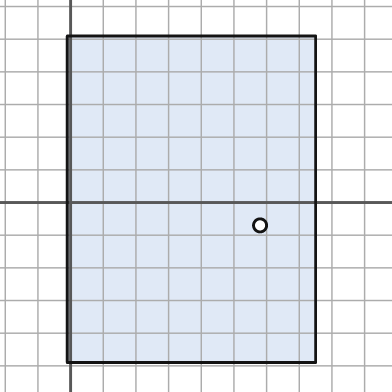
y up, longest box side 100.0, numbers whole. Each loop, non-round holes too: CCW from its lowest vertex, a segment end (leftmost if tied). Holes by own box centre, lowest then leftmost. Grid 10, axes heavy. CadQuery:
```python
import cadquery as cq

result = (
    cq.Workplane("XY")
    .moveTo(-1.0, -49.0)
    .lineTo(75.0, -49.0)
    .lineTo(75.0, 51.0)
    .lineTo(-1.0, 51.0)
    .close()
    .moveTo(58.0, -7.0)
    .circle(2.0)
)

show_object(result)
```